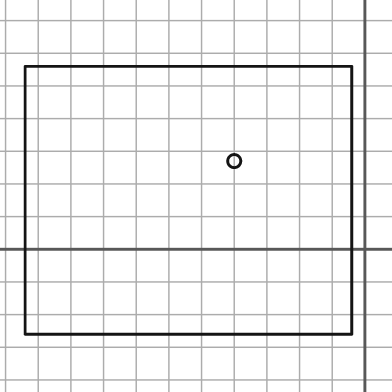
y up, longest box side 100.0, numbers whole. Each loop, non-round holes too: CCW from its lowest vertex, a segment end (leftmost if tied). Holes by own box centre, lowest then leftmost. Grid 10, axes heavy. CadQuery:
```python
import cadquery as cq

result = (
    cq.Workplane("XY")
    .moveTo(-104.0, -26.0)
    .lineTo(-4.0, -26.0)
    .lineTo(-4.0, 56.0)
    .lineTo(-104.0, 56.0)
    .close()
    .moveTo(-40.0, 27.0)
    .circle(2.0)
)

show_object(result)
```